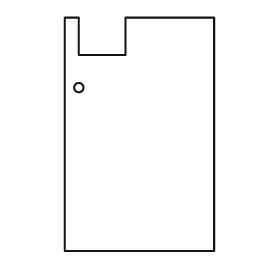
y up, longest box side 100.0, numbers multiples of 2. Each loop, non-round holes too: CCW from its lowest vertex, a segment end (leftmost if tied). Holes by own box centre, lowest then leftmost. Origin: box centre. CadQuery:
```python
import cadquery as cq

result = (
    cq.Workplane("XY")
    .moveTo(-32.0, -50.0)
    .lineTo(32.0, -50.0)
    .lineTo(32.0, 50.0)
    .lineTo(-6.0, 50.0)
    .lineTo(-6.0, 34.0)
    .lineTo(-26.0, 34.0)
    .lineTo(-26.0, 50.0)
    .lineTo(-32.0, 50.0)
    .close()
    .moveTo(-26.0, 20.0)
    .circle(2.0)
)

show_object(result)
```